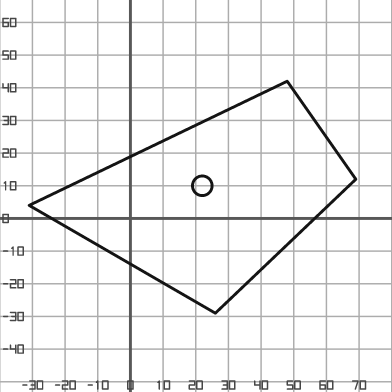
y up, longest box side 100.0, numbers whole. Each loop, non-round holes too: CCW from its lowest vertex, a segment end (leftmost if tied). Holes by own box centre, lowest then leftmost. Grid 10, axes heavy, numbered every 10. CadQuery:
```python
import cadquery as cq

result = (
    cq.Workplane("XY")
    .moveTo(26.0, -29.0)
    .lineTo(69.0, 12.0)
    .lineTo(48.0, 42.0)
    .lineTo(-31.0, 4.0)
    .close()
    .moveTo(22.0, 10.0)
    .circle(3.0)
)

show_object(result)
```